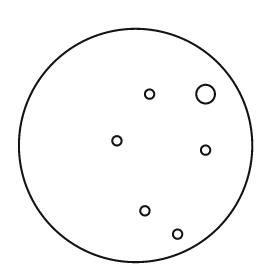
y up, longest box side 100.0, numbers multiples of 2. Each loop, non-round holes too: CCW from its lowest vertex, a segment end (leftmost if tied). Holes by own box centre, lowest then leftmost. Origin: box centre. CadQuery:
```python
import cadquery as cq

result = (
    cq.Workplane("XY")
    .moveTo(0.0, 0.0)
    .circle(50.0)
    .moveTo(18.0, -38.0)
    .circle(2.0)
    .moveTo(4.0, -28.0)
    .circle(2.0)
    .moveTo(30.0, -2.0)
    .circle(2.0)
    .moveTo(-8.0, 2.0)
    .circle(2.0)
    .moveTo(6.0, 22.0)
    .circle(2.0)
    .moveTo(30.0, 22.0)
    .circle(4.0)
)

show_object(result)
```